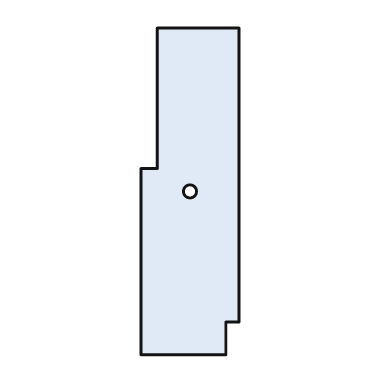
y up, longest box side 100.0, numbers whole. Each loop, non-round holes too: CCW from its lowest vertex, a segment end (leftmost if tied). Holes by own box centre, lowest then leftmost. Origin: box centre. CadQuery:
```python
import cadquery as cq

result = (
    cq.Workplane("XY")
    .moveTo(-15.0, -50.0)
    .lineTo(11.0, -50.0)
    .lineTo(11.0, -40.0)
    .lineTo(15.0, -40.0)
    .lineTo(15.0, 50.0)
    .lineTo(-10.0, 50.0)
    .lineTo(-10.0, 7.0)
    .lineTo(-15.0, 7.0)
    .close()
    .moveTo(0.0, 0.0)
    .circle(2.0)
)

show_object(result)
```